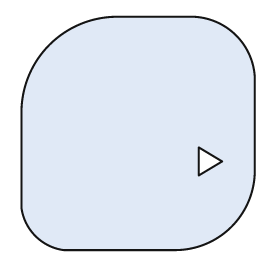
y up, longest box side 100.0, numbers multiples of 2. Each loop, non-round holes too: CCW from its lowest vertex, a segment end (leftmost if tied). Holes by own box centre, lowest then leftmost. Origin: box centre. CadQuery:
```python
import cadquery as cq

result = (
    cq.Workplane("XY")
    .moveTo(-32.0, -50.0)
    .lineTo(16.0, -50.0)
    .threePointArc((40.0, -40.0), (50.0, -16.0))
    .lineTo(50.0, 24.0)
    .threePointArc((42.0, 42.0), (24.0, 50.0))
    .lineTo(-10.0, 50.0)
    .threePointArc((-38.0, 38.0), (-50.0, 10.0))
    .lineTo(-50.0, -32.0)
    .threePointArc((-44.0, -44.0), (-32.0, -50.0))
    .close()
    .moveTo(26.0, -18.0)
    .lineTo(36.0, -12.0)
    .lineTo(26.0, -6.0)
    .close()
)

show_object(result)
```